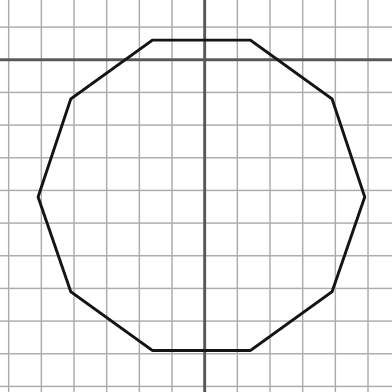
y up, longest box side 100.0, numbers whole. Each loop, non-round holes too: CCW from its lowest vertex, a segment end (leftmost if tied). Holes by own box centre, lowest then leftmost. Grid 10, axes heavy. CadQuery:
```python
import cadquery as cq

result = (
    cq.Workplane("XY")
    .moveTo(-16.0, -89.0)
    .lineTo(14.0, -89.0)
    .lineTo(39.0, -71.0)
    .lineTo(49.0, -42.0)
    .lineTo(39.0, -12.0)
    .lineTo(14.0, 6.0)
    .lineTo(-16.0, 6.0)
    .lineTo(-41.0, -12.0)
    .lineTo(-51.0, -42.0)
    .lineTo(-41.0, -71.0)
    .close()
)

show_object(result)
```